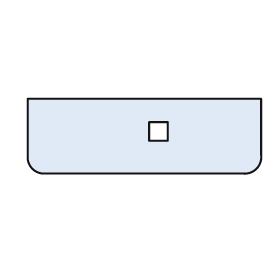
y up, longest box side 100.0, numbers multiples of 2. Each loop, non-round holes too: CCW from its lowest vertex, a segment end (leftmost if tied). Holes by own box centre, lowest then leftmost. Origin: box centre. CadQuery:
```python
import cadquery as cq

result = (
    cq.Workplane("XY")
    .moveTo(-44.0, -16.0)
    .lineTo(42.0, -16.0)
    .threePointArc((48.0, -14.0), (50.0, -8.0))
    .lineTo(50.0, 16.0)
    .lineTo(-50.0, 16.0)
    .lineTo(-50.0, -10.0)
    .threePointArc((-48.0, -14.0), (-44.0, -16.0))
    .close()
    .moveTo(2.0, -2.0)
    .lineTo(10.0, -2.0)
    .lineTo(10.0, 6.0)
    .lineTo(2.0, 6.0)
    .close()
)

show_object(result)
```